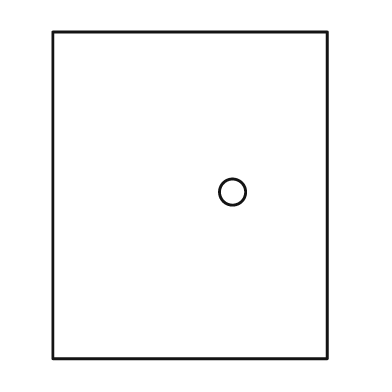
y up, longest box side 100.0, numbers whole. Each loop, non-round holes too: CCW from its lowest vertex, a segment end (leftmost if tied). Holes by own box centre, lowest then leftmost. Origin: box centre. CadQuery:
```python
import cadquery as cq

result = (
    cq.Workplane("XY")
    .moveTo(-42.0, -50.0)
    .lineTo(42.0, -50.0)
    .lineTo(42.0, 50.0)
    .lineTo(-42.0, 50.0)
    .close()
    .moveTo(13.0, 1.0)
    .circle(4.0)
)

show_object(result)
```